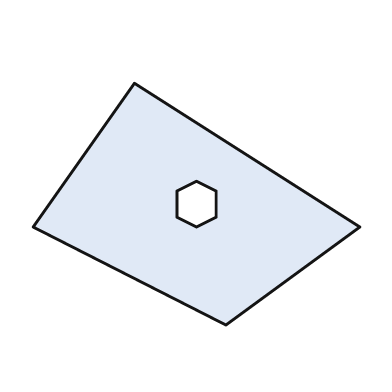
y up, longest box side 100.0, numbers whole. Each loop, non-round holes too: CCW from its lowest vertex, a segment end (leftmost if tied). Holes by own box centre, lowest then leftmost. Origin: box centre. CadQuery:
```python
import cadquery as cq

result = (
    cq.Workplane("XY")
    .moveTo(9.0, -37.0)
    .lineTo(50.0, -7.0)
    .lineTo(-19.0, 37.0)
    .lineTo(-50.0, -7.0)
    .close()
    .moveTo(0.0, -7.0)
    .lineTo(6.0, -4.0)
    .lineTo(6.0, 4.0)
    .lineTo(0.0, 7.0)
    .lineTo(-6.0, 4.0)
    .lineTo(-6.0, -4.0)
    .close()
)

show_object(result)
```